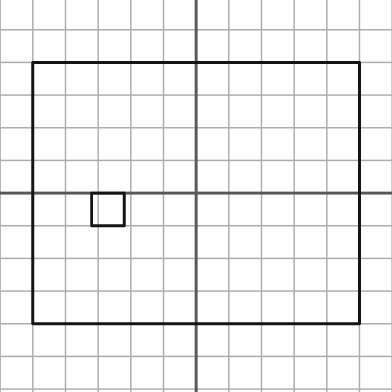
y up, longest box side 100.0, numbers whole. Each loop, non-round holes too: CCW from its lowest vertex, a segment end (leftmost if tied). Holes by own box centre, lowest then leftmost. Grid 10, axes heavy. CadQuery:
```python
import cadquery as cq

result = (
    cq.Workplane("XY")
    .moveTo(-50.0, -40.0)
    .lineTo(50.0, -40.0)
    .lineTo(50.0, 40.0)
    .lineTo(-50.0, 40.0)
    .close()
    .moveTo(-32.0, -10.0)
    .lineTo(-22.0, -10.0)
    .lineTo(-22.0, 0.0)
    .lineTo(-32.0, 0.0)
    .close()
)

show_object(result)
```